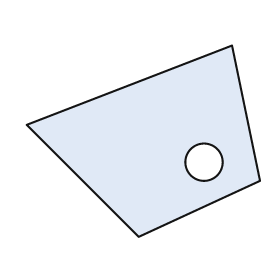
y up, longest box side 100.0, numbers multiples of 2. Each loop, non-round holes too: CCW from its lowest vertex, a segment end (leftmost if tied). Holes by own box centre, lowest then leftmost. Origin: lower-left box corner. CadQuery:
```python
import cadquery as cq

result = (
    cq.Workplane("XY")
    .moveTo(48.0, 0.0)
    .lineTo(100.0, 24.0)
    .lineTo(88.0, 82.0)
    .lineTo(0.0, 48.0)
    .close()
    .moveTo(76.0, 32.0)
    .circle(8.0)
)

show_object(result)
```